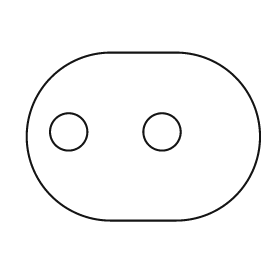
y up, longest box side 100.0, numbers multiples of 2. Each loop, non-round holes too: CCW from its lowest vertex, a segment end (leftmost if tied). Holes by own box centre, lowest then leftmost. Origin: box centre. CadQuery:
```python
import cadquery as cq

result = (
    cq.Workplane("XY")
    .moveTo(-14.0, -36.0)
    .lineTo(14.0, -36.0)
    .threePointArc((50.0, 0.0), (14.0, 36.0))
    .lineTo(-14.0, 36.0)
    .threePointArc((-50.0, 0.0), (-14.0, -36.0))
    .close()
    .moveTo(-32.0, 2.0)
    .circle(8.0)
    .moveTo(8.0, 2.0)
    .circle(8.0)
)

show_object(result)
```